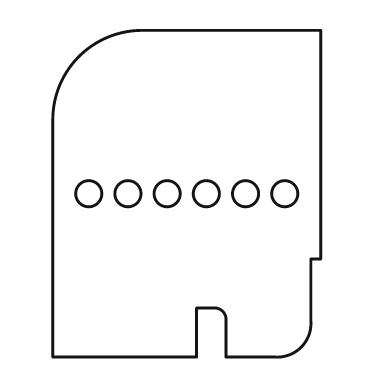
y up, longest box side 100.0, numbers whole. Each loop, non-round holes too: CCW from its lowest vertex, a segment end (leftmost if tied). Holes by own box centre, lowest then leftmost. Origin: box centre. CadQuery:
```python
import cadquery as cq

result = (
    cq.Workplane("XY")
    .moveTo(-41.0, -50.0)
    .lineTo(3.0, -50.0)
    .lineTo(3.0, -35.0)
    .lineTo(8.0, -35.0)
    .threePointArc((11.0, -36.0), (12.0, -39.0))
    .lineTo(12.0, -50.0)
    .lineTo(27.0, -50.0)
    .threePointArc((35.0, -47.0), (38.0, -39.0))
    .lineTo(38.0, -20.0)
    .lineTo(41.0, -20.0)
    .lineTo(41.0, 50.0)
    .lineTo(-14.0, 50.0)
    .threePointArc((-33.0, 42.0), (-41.0, 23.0))
    .close()
    .moveTo(-30.0, 0.0)
    .circle(4.0)
    .moveTo(-18.0, 0.0)
    .circle(4.0)
    .moveTo(-6.0, 0.0)
    .circle(4.0)
    .moveTo(6.0, 0.0)
    .circle(4.0)
    .moveTo(18.0, 0.0)
    .circle(4.0)
    .moveTo(30.0, 0.0)
    .circle(4.0)
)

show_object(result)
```